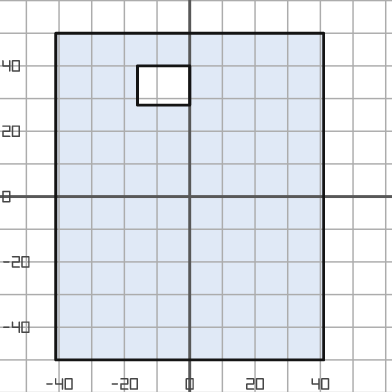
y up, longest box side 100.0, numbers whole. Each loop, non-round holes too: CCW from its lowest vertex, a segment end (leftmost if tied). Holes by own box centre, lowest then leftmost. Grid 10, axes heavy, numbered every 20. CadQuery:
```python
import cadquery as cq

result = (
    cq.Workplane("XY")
    .moveTo(-41.0, -50.0)
    .lineTo(41.0, -50.0)
    .lineTo(41.0, 50.0)
    .lineTo(-41.0, 50.0)
    .close()
    .moveTo(-16.0, 28.0)
    .lineTo(0.0, 28.0)
    .lineTo(0.0, 40.0)
    .lineTo(-16.0, 40.0)
    .close()
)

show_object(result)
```